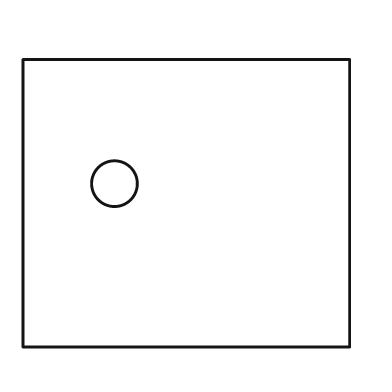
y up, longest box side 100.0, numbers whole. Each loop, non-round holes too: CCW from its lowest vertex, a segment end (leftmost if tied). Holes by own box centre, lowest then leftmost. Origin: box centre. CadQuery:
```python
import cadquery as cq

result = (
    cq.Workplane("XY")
    .moveTo(-50.0, -44.0)
    .lineTo(50.0, -44.0)
    .lineTo(50.0, 44.0)
    .lineTo(-50.0, 44.0)
    .close()
    .moveTo(-22.0, 6.0)
    .circle(7.0)
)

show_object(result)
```